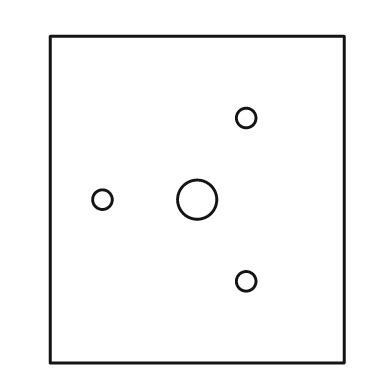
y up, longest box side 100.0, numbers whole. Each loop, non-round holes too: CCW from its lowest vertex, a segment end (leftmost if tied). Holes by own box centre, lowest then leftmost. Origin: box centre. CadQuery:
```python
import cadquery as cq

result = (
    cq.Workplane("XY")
    .moveTo(-45.0, -50.0)
    .lineTo(45.0, -50.0)
    .lineTo(45.0, 50.0)
    .lineTo(-45.0, 50.0)
    .close()
    .moveTo(15.0, -25.0)
    .circle(3.0)
    .moveTo(-29.0, 0.0)
    .circle(3.0)
    .moveTo(0.0, 0.0)
    .circle(6.0)
    .moveTo(15.0, 25.0)
    .circle(3.0)
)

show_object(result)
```